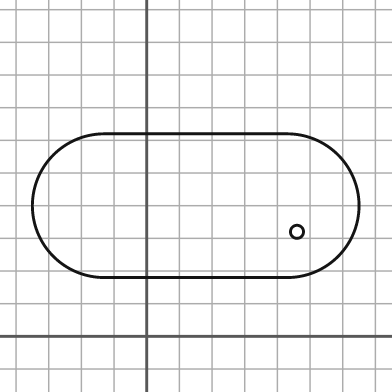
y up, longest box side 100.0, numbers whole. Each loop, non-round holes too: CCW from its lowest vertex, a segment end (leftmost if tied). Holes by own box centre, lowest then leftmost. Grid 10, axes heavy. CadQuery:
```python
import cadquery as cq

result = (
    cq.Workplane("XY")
    .moveTo(-13.0, 18.0)
    .lineTo(43.0, 18.0)
    .threePointArc((65.0, 40.0), (43.0, 62.0))
    .lineTo(-13.0, 62.0)
    .threePointArc((-35.0, 40.0), (-13.0, 18.0))
    .close()
    .moveTo(46.0, 32.0)
    .circle(2.0)
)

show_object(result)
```